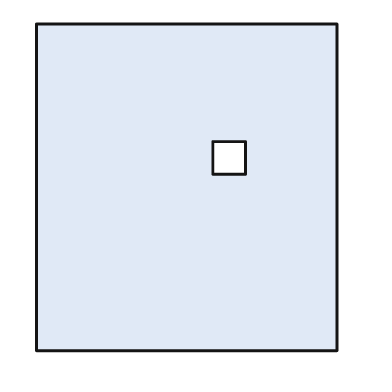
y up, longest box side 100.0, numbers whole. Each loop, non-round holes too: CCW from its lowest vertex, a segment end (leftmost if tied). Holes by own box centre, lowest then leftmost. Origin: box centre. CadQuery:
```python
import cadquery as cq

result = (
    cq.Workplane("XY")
    .moveTo(-46.0, -50.0)
    .lineTo(46.0, -50.0)
    .lineTo(46.0, 50.0)
    .lineTo(-46.0, 50.0)
    .close()
    .moveTo(8.0, 4.0)
    .lineTo(18.0, 4.0)
    .lineTo(18.0, 14.0)
    .lineTo(8.0, 14.0)
    .close()
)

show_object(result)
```